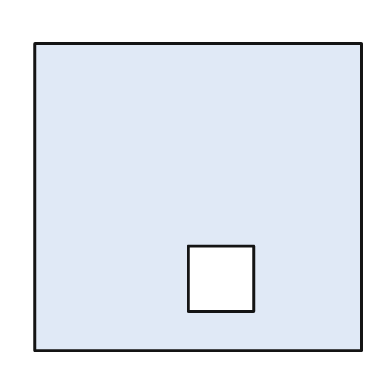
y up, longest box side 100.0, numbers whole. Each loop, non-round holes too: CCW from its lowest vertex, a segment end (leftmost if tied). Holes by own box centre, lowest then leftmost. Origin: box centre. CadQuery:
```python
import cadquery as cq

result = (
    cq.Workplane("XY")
    .moveTo(-50.0, -47.0)
    .lineTo(50.0, -47.0)
    .lineTo(50.0, 47.0)
    .lineTo(-50.0, 47.0)
    .close()
    .moveTo(-3.0, -35.0)
    .lineTo(17.0, -35.0)
    .lineTo(17.0, -15.0)
    .lineTo(-3.0, -15.0)
    .close()
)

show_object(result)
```